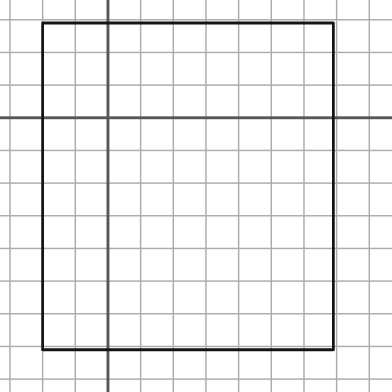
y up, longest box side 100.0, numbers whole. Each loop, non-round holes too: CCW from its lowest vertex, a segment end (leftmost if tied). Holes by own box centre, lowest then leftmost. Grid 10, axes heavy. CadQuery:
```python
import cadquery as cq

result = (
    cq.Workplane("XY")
    .moveTo(-20.0, -71.0)
    .lineTo(69.0, -71.0)
    .lineTo(69.0, 29.0)
    .lineTo(-20.0, 29.0)
    .close()
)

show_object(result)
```